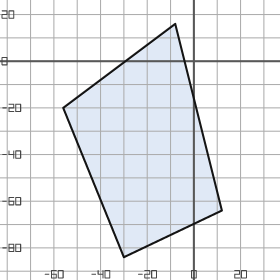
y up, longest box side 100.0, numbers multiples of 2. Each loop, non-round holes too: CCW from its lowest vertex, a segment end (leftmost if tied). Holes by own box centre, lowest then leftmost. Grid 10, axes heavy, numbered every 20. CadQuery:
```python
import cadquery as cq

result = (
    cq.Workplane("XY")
    .moveTo(-30.0, -84.0)
    .lineTo(12.0, -64.0)
    .lineTo(-8.0, 16.0)
    .lineTo(-56.0, -20.0)
    .close()
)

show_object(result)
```